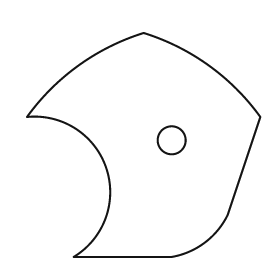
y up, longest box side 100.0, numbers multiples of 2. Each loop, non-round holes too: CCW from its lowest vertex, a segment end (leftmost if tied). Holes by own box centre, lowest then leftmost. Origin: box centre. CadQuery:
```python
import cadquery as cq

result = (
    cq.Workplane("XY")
    .moveTo(-30.0, -48.0)
    .lineTo(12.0, -48.0)
    .threePointArc((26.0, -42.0), (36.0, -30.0))
    .lineTo(50.0, 12.0)
    .threePointArc((28.0, 34.0), (0.0, 48.0))
    .threePointArc((-28.0, 34.0), (-50.0, 12.0))
    .threePointArc((-16.0, -10.0), (-30.0, -48.0))
    .close()
    .moveTo(12.0, 2.0)
    .circle(6.0)
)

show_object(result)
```